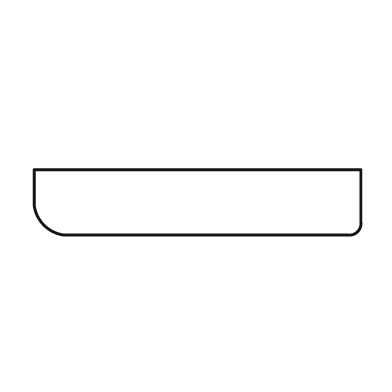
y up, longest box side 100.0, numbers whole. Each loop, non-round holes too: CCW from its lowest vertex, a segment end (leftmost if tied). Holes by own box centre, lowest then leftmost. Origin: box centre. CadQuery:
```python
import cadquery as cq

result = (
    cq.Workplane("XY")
    .moveTo(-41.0, -10.0)
    .lineTo(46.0, -10.0)
    .threePointArc((49.0, -9.0), (50.0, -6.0))
    .lineTo(50.0, 10.0)
    .lineTo(-50.0, 10.0)
    .lineTo(-50.0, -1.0)
    .threePointArc((-47.0, -7.0), (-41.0, -10.0))
    .close()
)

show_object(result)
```